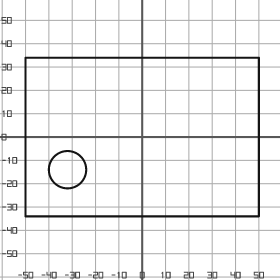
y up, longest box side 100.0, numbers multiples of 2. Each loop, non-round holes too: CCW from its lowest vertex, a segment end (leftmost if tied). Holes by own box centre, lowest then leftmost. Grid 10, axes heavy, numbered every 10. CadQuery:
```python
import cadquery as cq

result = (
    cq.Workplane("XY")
    .moveTo(-50.0, -34.0)
    .lineTo(50.0, -34.0)
    .lineTo(50.0, 34.0)
    .lineTo(-50.0, 34.0)
    .close()
    .moveTo(-32.0, -14.0)
    .circle(8.0)
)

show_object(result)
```